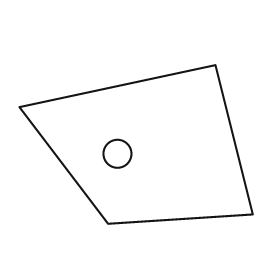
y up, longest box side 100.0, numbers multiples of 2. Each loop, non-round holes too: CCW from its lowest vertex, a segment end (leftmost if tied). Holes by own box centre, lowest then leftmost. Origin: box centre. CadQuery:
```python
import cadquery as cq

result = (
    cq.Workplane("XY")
    .moveTo(-12.0, -34.0)
    .lineTo(50.0, -30.0)
    .lineTo(34.0, 34.0)
    .lineTo(-50.0, 16.0)
    .close()
    .moveTo(-8.0, -4.0)
    .circle(6.0)
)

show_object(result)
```